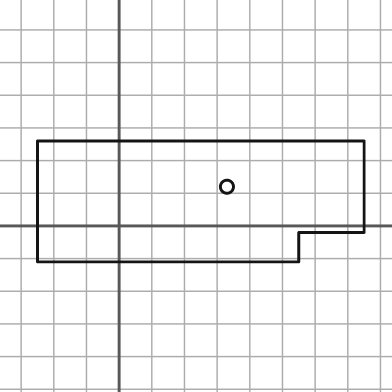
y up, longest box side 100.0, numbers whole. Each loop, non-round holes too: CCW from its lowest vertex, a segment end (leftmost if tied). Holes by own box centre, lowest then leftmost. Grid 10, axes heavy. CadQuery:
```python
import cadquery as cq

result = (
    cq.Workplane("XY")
    .moveTo(-25.0, -11.0)
    .lineTo(55.0, -11.0)
    .lineTo(55.0, -2.0)
    .lineTo(75.0, -2.0)
    .lineTo(75.0, 26.0)
    .lineTo(-25.0, 26.0)
    .close()
    .moveTo(33.0, 12.0)
    .circle(2.0)
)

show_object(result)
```